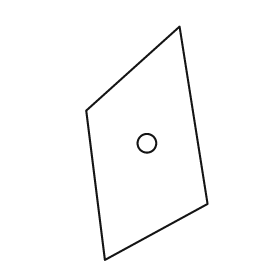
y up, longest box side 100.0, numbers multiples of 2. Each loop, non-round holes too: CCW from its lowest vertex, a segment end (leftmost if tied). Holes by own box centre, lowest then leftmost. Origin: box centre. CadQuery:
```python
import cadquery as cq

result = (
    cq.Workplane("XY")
    .moveTo(-18.0, -50.0)
    .lineTo(26.0, -26.0)
    .lineTo(14.0, 50.0)
    .lineTo(-26.0, 14.0)
    .close()
    .moveTo(0.0, 0.0)
    .circle(4.0)
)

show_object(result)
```